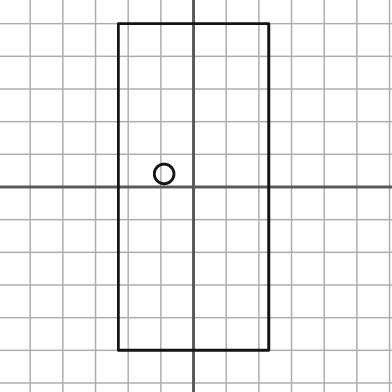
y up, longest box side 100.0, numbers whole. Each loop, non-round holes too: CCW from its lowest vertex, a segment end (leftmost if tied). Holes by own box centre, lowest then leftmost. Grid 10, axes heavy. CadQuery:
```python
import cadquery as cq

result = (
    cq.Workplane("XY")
    .moveTo(-23.0, -50.0)
    .lineTo(23.0, -50.0)
    .lineTo(23.0, 50.0)
    .lineTo(-23.0, 50.0)
    .close()
    .moveTo(-9.0, 4.0)
    .circle(3.0)
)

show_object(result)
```